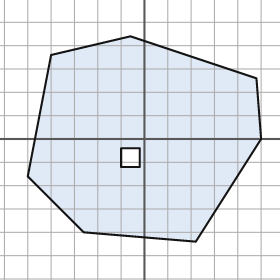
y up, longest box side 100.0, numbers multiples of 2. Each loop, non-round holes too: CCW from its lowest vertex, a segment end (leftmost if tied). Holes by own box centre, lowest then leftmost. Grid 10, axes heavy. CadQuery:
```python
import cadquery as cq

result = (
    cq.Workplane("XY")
    .moveTo(22.0, -44.0)
    .lineTo(50.0, 0.0)
    .lineTo(48.0, 26.0)
    .lineTo(-6.0, 44.0)
    .lineTo(-40.0, 36.0)
    .lineTo(-50.0, -16.0)
    .lineTo(-26.0, -40.0)
    .close()
    .moveTo(-10.0, -12.0)
    .lineTo(-2.0, -12.0)
    .lineTo(-2.0, -4.0)
    .lineTo(-10.0, -4.0)
    .close()
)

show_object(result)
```